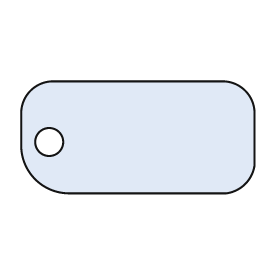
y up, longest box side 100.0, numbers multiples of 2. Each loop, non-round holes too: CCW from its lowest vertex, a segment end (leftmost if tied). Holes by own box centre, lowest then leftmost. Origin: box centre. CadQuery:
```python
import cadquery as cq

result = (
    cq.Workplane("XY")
    .moveTo(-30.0, -24.0)
    .lineTo(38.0, -24.0)
    .threePointArc((46.0, -20.0), (50.0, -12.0))
    .lineTo(50.0, 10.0)
    .threePointArc((46.0, 20.0), (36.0, 24.0))
    .lineTo(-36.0, 24.0)
    .threePointArc((-46.0, 20.0), (-50.0, 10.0))
    .lineTo(-50.0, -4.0)
    .threePointArc((-44.0, -18.0), (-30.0, -24.0))
    .close()
    .moveTo(-38.0, -2.0)
    .circle(6.0)
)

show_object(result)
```